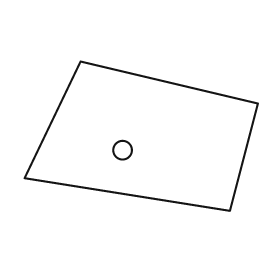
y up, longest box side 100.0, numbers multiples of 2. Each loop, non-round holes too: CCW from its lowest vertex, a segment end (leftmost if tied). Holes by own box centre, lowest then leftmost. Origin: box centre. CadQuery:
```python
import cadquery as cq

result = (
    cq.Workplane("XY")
    .moveTo(38.0, -32.0)
    .lineTo(50.0, 14.0)
    .lineTo(-26.0, 32.0)
    .lineTo(-50.0, -18.0)
    .close()
    .moveTo(-8.0, -6.0)
    .circle(4.0)
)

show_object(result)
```